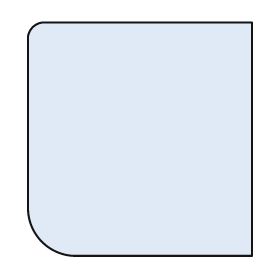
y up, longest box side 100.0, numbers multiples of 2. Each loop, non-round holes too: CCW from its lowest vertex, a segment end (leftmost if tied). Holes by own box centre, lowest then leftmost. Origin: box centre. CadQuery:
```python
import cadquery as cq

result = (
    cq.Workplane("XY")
    .moveTo(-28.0, -50.0)
    .lineTo(48.0, -50.0)
    .lineTo(48.0, 50.0)
    .lineTo(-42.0, 50.0)
    .threePointArc((-46.0, 48.0), (-48.0, 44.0))
    .lineTo(-48.0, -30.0)
    .threePointArc((-42.0, -44.0), (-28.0, -50.0))
    .close()
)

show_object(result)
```